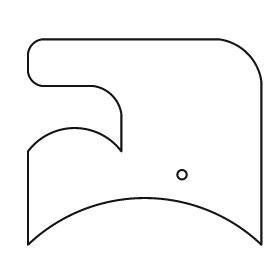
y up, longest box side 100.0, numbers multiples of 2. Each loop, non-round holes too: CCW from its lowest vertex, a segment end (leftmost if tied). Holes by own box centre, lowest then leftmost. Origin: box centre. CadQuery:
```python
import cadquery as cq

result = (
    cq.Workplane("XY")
    .moveTo(-50.0, -44.0)
    .threePointArc((0.0, -24.0), (50.0, -44.0))
    .lineTo(50.0, 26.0)
    .threePointArc((44.0, 38.0), (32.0, 44.0))
    .lineTo(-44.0, 44.0)
    .threePointArc((-48.0, 42.0), (-50.0, 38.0))
    .lineTo(-50.0, 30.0)
    .threePointArc((-48.0, 26.0), (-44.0, 24.0))
    .lineTo(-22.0, 24.0)
    .threePointArc((-14.0, 20.0), (-10.0, 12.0))
    .lineTo(-10.0, -4.0)
    .threePointArc((-30.0, 6.0), (-50.0, -4.0))
    .close()
    .moveTo(16.0, -14.0)
    .circle(2.0)
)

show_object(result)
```